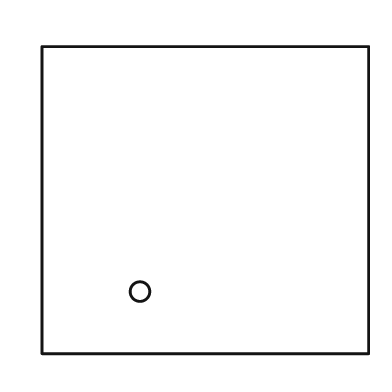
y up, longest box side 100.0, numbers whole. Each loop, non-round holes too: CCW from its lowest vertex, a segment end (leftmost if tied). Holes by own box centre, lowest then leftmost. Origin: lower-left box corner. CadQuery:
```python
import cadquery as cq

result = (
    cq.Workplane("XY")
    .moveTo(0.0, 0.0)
    .lineTo(100.0, 0.0)
    .lineTo(100.0, 94.0)
    .lineTo(0.0, 94.0)
    .close()
    .moveTo(30.0, 19.0)
    .circle(3.0)
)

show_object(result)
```